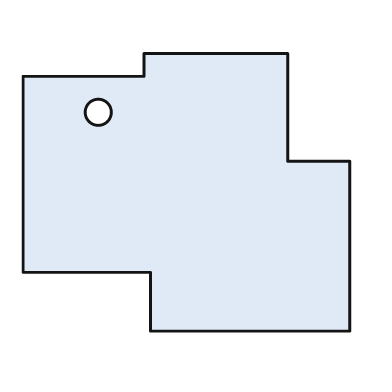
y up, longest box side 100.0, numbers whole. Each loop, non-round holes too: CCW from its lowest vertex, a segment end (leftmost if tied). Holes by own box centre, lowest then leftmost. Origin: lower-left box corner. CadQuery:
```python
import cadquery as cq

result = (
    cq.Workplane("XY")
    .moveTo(39.0, 0.0)
    .lineTo(100.0, 0.0)
    .lineTo(100.0, 52.0)
    .lineTo(81.0, 52.0)
    .lineTo(81.0, 85.0)
    .lineTo(37.0, 85.0)
    .lineTo(37.0, 78.0)
    .lineTo(0.0, 78.0)
    .lineTo(0.0, 18.0)
    .lineTo(39.0, 18.0)
    .close()
    .moveTo(23.0, 67.0)
    .circle(4.0)
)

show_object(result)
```